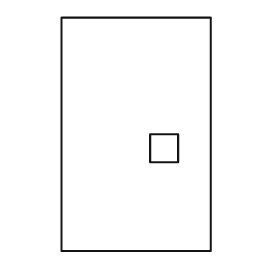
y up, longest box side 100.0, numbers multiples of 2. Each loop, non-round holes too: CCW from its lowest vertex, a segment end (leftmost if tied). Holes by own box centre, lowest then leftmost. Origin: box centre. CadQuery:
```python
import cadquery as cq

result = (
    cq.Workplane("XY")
    .moveTo(-32.0, -50.0)
    .lineTo(32.0, -50.0)
    .lineTo(32.0, 50.0)
    .lineTo(-32.0, 50.0)
    .close()
    .moveTo(6.0, -12.0)
    .lineTo(18.0, -12.0)
    .lineTo(18.0, 0.0)
    .lineTo(6.0, 0.0)
    .close()
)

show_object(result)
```